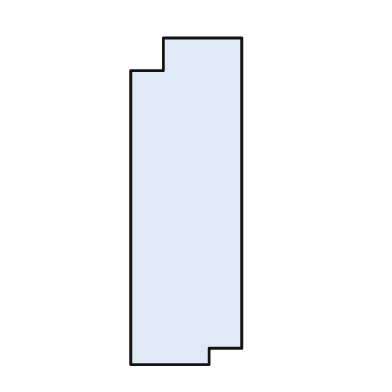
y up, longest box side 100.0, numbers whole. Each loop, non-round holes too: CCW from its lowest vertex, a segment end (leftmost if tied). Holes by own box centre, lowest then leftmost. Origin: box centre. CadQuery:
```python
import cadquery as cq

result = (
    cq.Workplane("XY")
    .moveTo(-17.0, -50.0)
    .lineTo(7.0, -50.0)
    .lineTo(7.0, -45.0)
    .lineTo(17.0, -45.0)
    .lineTo(17.0, 50.0)
    .lineTo(-7.0, 50.0)
    .lineTo(-7.0, 40.0)
    .lineTo(-17.0, 40.0)
    .close()
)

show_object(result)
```